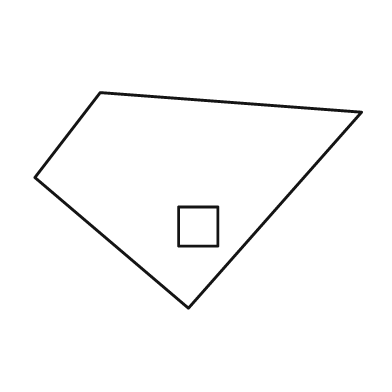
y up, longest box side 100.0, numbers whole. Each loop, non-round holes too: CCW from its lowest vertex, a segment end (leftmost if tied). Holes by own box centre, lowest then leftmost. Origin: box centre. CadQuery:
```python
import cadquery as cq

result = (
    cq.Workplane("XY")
    .moveTo(-3.0, -33.0)
    .lineTo(50.0, 27.0)
    .lineTo(-30.0, 33.0)
    .lineTo(-50.0, 7.0)
    .close()
    .moveTo(-6.0, -14.0)
    .lineTo(6.0, -14.0)
    .lineTo(6.0, -2.0)
    .lineTo(-6.0, -2.0)
    .close()
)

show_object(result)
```